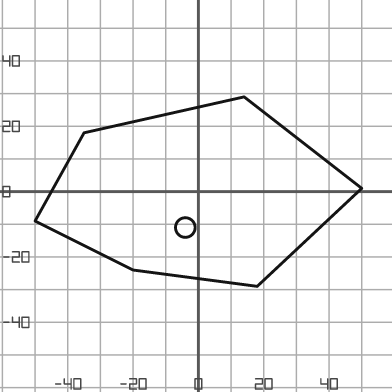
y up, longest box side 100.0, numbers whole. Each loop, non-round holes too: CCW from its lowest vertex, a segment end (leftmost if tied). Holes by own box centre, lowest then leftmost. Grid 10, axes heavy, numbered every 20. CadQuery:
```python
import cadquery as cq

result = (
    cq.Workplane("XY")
    .moveTo(18.0, -29.0)
    .lineTo(50.0, 1.0)
    .lineTo(14.0, 29.0)
    .lineTo(-35.0, 18.0)
    .lineTo(-50.0, -9.0)
    .lineTo(-20.0, -24.0)
    .close()
    .moveTo(-4.0, -11.0)
    .circle(3.0)
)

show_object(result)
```